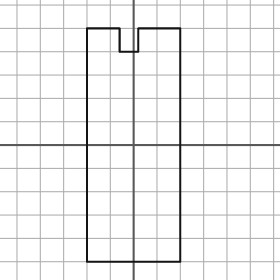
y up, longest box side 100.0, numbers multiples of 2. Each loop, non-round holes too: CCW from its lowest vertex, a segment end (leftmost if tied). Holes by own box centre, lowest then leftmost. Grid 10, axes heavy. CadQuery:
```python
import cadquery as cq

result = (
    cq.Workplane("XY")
    .moveTo(-20.0, -50.0)
    .lineTo(20.0, -50.0)
    .lineTo(20.0, 50.0)
    .lineTo(2.0, 50.0)
    .lineTo(2.0, 40.0)
    .lineTo(-6.0, 40.0)
    .lineTo(-6.0, 50.0)
    .lineTo(-20.0, 50.0)
    .close()
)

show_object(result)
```